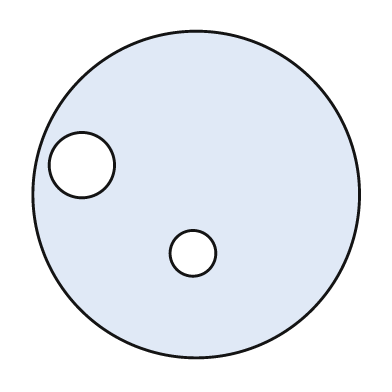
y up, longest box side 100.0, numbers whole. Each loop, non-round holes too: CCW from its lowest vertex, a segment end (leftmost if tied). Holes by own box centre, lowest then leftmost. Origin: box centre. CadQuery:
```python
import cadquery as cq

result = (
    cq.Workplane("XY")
    .moveTo(0.0, 0.0)
    .circle(50.0)
    .moveTo(-1.0, -18.0)
    .circle(7.0)
    .moveTo(-35.0, 9.0)
    .circle(10.0)
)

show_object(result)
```